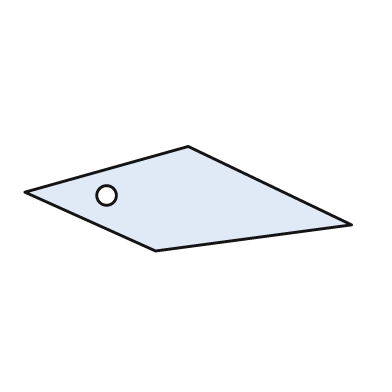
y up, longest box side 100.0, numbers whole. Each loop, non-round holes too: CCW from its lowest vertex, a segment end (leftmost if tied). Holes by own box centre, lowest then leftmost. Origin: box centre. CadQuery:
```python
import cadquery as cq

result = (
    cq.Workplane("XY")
    .moveTo(-10.0, -16.0)
    .lineTo(50.0, -8.0)
    .lineTo(0.0, 16.0)
    .lineTo(-50.0, 2.0)
    .close()
    .moveTo(-25.0, 1.0)
    .circle(3.0)
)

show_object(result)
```